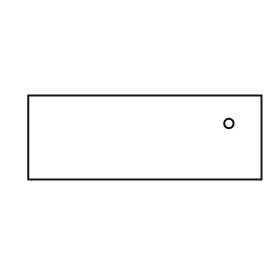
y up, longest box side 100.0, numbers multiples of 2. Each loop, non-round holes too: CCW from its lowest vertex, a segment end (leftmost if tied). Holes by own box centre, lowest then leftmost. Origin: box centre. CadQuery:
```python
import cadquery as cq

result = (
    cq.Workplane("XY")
    .moveTo(-50.0, -18.0)
    .lineTo(50.0, -18.0)
    .lineTo(50.0, 18.0)
    .lineTo(-50.0, 18.0)
    .close()
    .moveTo(36.0, 6.0)
    .circle(2.0)
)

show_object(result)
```